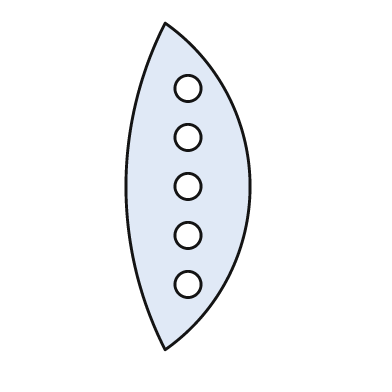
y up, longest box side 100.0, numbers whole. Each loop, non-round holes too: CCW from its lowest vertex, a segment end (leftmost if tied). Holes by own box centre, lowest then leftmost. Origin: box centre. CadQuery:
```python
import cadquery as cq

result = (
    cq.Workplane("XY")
    .moveTo(-7.0, -50.0)
    .threePointArc((19.0, 0.0), (-7.0, 50.0))
    .threePointArc((-19.0, 0.0), (-7.0, -50.0))
    .close()
    .moveTo(0.0, -30.0)
    .circle(4.0)
    .moveTo(0.0, -15.0)
    .circle(4.0)
    .moveTo(0.0, 0.0)
    .circle(4.0)
    .moveTo(0.0, 15.0)
    .circle(4.0)
    .moveTo(0.0, 30.0)
    .circle(4.0)
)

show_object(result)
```